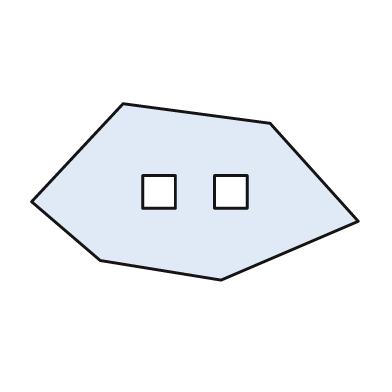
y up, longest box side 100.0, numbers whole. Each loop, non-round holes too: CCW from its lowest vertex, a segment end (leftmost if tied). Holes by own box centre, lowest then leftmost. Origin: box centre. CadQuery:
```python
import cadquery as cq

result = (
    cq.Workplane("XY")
    .moveTo(8.0, -27.0)
    .lineTo(50.0, -9.0)
    .lineTo(23.0, 21.0)
    .lineTo(-22.0, 27.0)
    .lineTo(-50.0, -3.0)
    .lineTo(-29.0, -21.0)
    .close()
    .moveTo(-16.0, -5.0)
    .lineTo(-6.0, -5.0)
    .lineTo(-6.0, 5.0)
    .lineTo(-16.0, 5.0)
    .close()
    .moveTo(6.0, -5.0)
    .lineTo(16.0, -5.0)
    .lineTo(16.0, 5.0)
    .lineTo(6.0, 5.0)
    .close()
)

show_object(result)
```